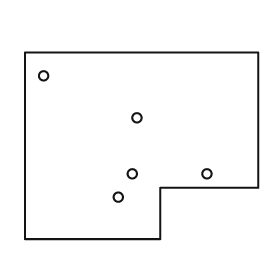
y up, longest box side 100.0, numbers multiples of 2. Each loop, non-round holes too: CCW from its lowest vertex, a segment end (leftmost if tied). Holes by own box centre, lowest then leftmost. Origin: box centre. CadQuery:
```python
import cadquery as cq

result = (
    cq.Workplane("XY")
    .moveTo(-50.0, -40.0)
    .lineTo(8.0, -40.0)
    .lineTo(8.0, -18.0)
    .lineTo(50.0, -18.0)
    .lineTo(50.0, 40.0)
    .lineTo(-50.0, 40.0)
    .close()
    .moveTo(-10.0, -22.0)
    .circle(2.0)
    .moveTo(-4.0, -12.0)
    .circle(2.0)
    .moveTo(28.0, -12.0)
    .circle(2.0)
    .moveTo(-2.0, 12.0)
    .circle(2.0)
    .moveTo(-42.0, 30.0)
    .circle(2.0)
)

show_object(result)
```